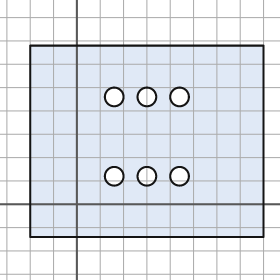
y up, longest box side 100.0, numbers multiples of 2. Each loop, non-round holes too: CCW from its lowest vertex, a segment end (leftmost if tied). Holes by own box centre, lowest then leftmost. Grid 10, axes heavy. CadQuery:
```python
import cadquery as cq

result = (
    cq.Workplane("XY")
    .moveTo(-20.0, -14.0)
    .lineTo(80.0, -14.0)
    .lineTo(80.0, 68.0)
    .lineTo(-20.0, 68.0)
    .close()
    .moveTo(16.0, 12.0)
    .circle(4.0)
    .moveTo(30.0, 12.0)
    .circle(4.0)
    .moveTo(44.0, 12.0)
    .circle(4.0)
    .moveTo(16.0, 46.0)
    .circle(4.0)
    .moveTo(30.0, 46.0)
    .circle(4.0)
    .moveTo(44.0, 46.0)
    .circle(4.0)
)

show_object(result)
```